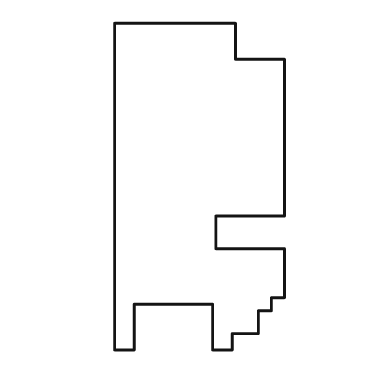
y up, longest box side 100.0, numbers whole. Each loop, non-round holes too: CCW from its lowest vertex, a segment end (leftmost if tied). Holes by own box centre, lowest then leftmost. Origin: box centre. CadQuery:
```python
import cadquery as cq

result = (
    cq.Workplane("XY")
    .moveTo(-26.0, -50.0)
    .lineTo(-20.0, -50.0)
    .lineTo(-20.0, -36.0)
    .lineTo(4.0, -36.0)
    .lineTo(4.0, -50.0)
    .lineTo(10.0, -50.0)
    .lineTo(10.0, -45.0)
    .lineTo(18.0, -45.0)
    .lineTo(18.0, -38.0)
    .lineTo(22.0, -38.0)
    .lineTo(22.0, -34.0)
    .lineTo(26.0, -34.0)
    .lineTo(26.0, -19.0)
    .lineTo(5.0, -19.0)
    .lineTo(5.0, -9.0)
    .lineTo(26.0, -9.0)
    .lineTo(26.0, 39.0)
    .lineTo(11.0, 39.0)
    .lineTo(11.0, 50.0)
    .lineTo(-26.0, 50.0)
    .close()
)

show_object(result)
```